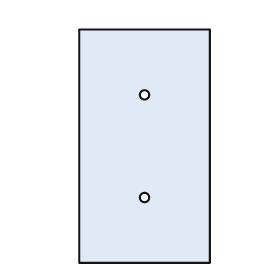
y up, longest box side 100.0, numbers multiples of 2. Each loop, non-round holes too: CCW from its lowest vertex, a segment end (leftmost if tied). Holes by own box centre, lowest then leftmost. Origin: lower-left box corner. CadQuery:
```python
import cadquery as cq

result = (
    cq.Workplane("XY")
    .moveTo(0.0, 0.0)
    .lineTo(56.0, 0.0)
    .lineTo(56.0, 100.0)
    .lineTo(0.0, 100.0)
    .close()
    .moveTo(28.0, 28.0)
    .circle(2.0)
    .moveTo(28.0, 72.0)
    .circle(2.0)
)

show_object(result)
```